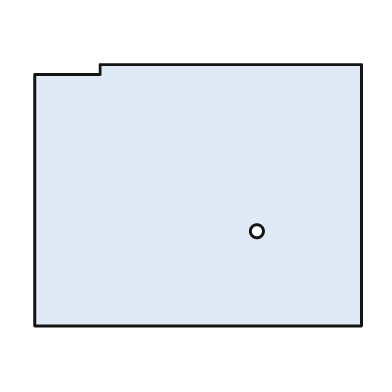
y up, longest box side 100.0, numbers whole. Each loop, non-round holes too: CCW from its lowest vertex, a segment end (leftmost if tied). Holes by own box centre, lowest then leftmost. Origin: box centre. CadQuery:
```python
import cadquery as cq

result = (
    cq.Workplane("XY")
    .moveTo(-50.0, -40.0)
    .lineTo(50.0, -40.0)
    .lineTo(50.0, 40.0)
    .lineTo(-30.0, 40.0)
    .lineTo(-30.0, 37.0)
    .lineTo(-50.0, 37.0)
    .close()
    .moveTo(18.0, -11.0)
    .circle(2.0)
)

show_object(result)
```